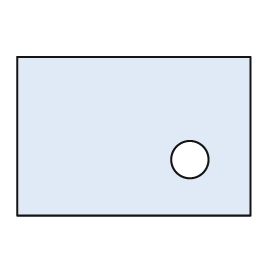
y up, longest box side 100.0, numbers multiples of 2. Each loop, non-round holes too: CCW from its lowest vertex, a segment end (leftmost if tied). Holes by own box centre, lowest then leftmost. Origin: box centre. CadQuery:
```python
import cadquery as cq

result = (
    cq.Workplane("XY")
    .moveTo(-50.0, -34.0)
    .lineTo(50.0, -34.0)
    .lineTo(50.0, 34.0)
    .lineTo(-50.0, 34.0)
    .close()
    .moveTo(24.0, -10.0)
    .circle(8.0)
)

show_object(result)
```